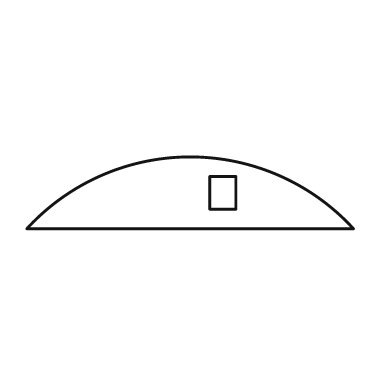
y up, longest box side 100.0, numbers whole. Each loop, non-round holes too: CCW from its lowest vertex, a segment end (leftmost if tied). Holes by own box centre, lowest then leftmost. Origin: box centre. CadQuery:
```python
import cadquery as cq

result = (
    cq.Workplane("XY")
    .moveTo(-50.0, -11.0)
    .lineTo(50.0, -11.0)
    .threePointArc((0.0, 11.0), (-50.0, -11.0))
    .close()
    .moveTo(6.0, -5.0)
    .lineTo(14.0, -5.0)
    .lineTo(14.0, 5.0)
    .lineTo(6.0, 5.0)
    .close()
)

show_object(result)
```